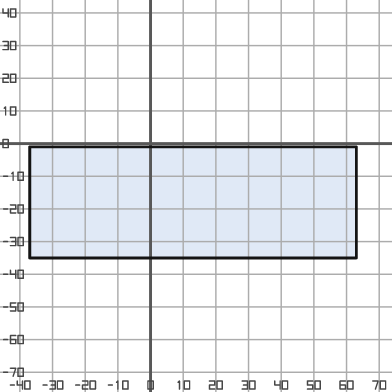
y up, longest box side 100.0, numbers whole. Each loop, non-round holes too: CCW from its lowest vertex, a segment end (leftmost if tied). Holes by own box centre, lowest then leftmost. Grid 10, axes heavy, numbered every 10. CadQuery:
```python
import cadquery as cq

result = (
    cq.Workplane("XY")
    .moveTo(-37.0, -35.0)
    .lineTo(63.0, -35.0)
    .lineTo(63.0, -1.0)
    .lineTo(-37.0, -1.0)
    .close()
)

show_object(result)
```